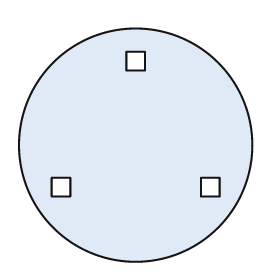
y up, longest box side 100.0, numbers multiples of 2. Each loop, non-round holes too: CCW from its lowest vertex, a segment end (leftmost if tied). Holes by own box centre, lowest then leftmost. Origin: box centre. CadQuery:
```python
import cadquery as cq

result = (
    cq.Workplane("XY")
    .moveTo(0.0, 0.0)
    .circle(50.0)
    .moveTo(-36.0, -22.0)
    .lineTo(-28.0, -22.0)
    .lineTo(-28.0, -14.0)
    .lineTo(-36.0, -14.0)
    .close()
    .moveTo(28.0, -22.0)
    .lineTo(36.0, -22.0)
    .lineTo(36.0, -14.0)
    .lineTo(28.0, -14.0)
    .close()
    .moveTo(-4.0, 32.0)
    .lineTo(4.0, 32.0)
    .lineTo(4.0, 40.0)
    .lineTo(-4.0, 40.0)
    .close()
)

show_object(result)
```